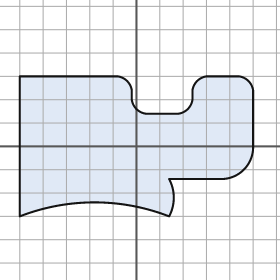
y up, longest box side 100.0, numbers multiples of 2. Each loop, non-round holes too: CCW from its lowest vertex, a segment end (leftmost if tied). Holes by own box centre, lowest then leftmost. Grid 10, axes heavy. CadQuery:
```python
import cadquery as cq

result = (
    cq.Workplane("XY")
    .moveTo(-50.0, -30.0)
    .threePointArc((-18.0, -24.0), (14.0, -30.0))
    .threePointArc((16.0, -22.0), (14.0, -14.0))
    .lineTo(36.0, -14.0)
    .threePointArc((46.0, -10.0), (50.0, 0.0))
    .lineTo(50.0, 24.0)
    .threePointArc((48.0, 28.0), (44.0, 30.0))
    .lineTo(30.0, 30.0)
    .threePointArc((26.0, 28.0), (24.0, 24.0))
    .lineTo(24.0, 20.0)
    .threePointArc((22.0, 16.0), (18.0, 14.0))
    .lineTo(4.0, 14.0)
    .threePointArc((0.0, 16.0), (-2.0, 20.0))
    .lineTo(-2.0, 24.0)
    .threePointArc((-4.0, 28.0), (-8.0, 30.0))
    .lineTo(-50.0, 30.0)
    .close()
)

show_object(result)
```